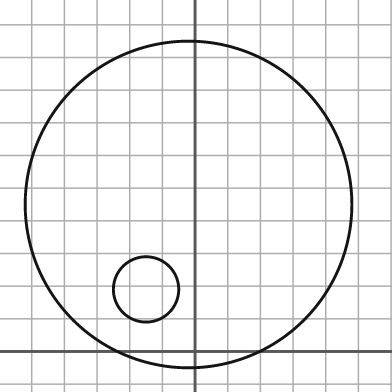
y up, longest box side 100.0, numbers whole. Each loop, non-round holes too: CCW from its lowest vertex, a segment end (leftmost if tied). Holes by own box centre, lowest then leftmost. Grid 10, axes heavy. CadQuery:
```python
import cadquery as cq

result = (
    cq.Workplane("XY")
    .moveTo(-2.0, 45.0)
    .circle(50.0)
    .moveTo(-15.0, 19.0)
    .circle(10.0)
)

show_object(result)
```